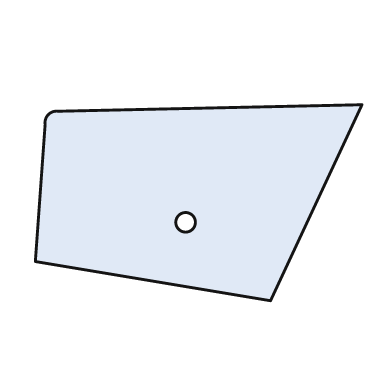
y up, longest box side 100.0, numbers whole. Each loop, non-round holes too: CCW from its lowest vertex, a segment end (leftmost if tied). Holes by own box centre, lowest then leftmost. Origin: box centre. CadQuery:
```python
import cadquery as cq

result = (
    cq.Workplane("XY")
    .moveTo(22.0, -30.0)
    .lineTo(50.0, 30.0)
    .lineTo(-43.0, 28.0)
    .threePointArc((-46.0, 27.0), (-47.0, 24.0))
    .lineTo(-50.0, -18.0)
    .close()
    .moveTo(-4.0, -6.0)
    .circle(3.0)
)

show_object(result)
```